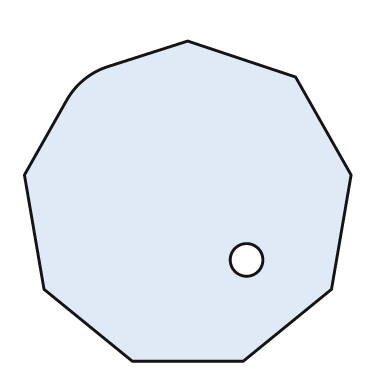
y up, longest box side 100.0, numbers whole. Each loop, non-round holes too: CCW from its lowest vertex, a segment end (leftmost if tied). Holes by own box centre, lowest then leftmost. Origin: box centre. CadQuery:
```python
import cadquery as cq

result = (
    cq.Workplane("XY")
    .moveTo(-17.0, -49.0)
    .lineTo(17.0, -49.0)
    .lineTo(44.0, -27.0)
    .lineTo(50.0, 8.0)
    .lineTo(33.0, 38.0)
    .lineTo(0.0, 49.0)
    .lineTo(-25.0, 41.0)
    .threePointArc((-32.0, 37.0), (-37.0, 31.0))
    .lineTo(-50.0, 8.0)
    .lineTo(-44.0, -27.0)
    .close()
    .moveTo(18.0, -18.0)
    .circle(5.0)
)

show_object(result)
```